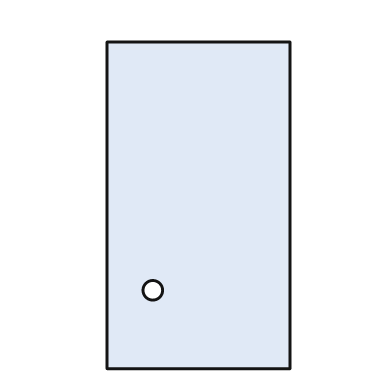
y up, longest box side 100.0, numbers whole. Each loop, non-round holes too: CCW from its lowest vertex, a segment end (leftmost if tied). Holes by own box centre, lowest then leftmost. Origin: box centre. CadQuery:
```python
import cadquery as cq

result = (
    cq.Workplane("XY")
    .moveTo(-28.0, -50.0)
    .lineTo(28.0, -50.0)
    .lineTo(28.0, 50.0)
    .lineTo(-28.0, 50.0)
    .close()
    .moveTo(-14.0, -26.0)
    .circle(3.0)
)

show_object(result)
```